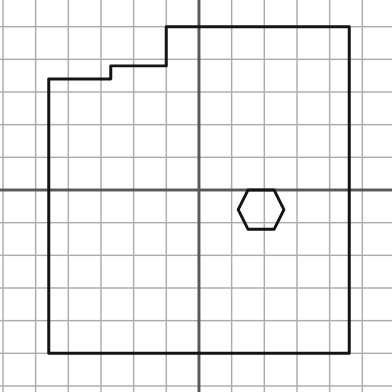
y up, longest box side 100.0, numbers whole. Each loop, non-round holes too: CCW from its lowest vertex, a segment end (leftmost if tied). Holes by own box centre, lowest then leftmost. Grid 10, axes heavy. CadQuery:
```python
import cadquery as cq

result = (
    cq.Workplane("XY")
    .moveTo(-46.0, -50.0)
    .lineTo(46.0, -50.0)
    .lineTo(46.0, 50.0)
    .lineTo(-10.0, 50.0)
    .lineTo(-10.0, 38.0)
    .lineTo(-27.0, 38.0)
    .lineTo(-27.0, 34.0)
    .lineTo(-46.0, 34.0)
    .close()
    .moveTo(15.0, -12.0)
    .lineTo(23.0, -12.0)
    .lineTo(26.0, -6.0)
    .lineTo(23.0, 0.0)
    .lineTo(15.0, 0.0)
    .lineTo(12.0, -6.0)
    .close()
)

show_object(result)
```